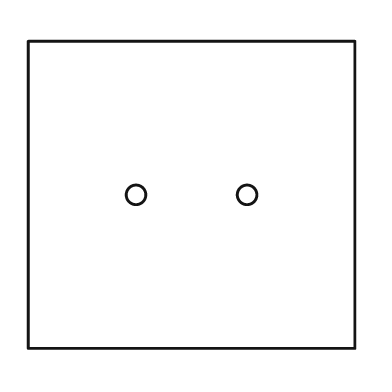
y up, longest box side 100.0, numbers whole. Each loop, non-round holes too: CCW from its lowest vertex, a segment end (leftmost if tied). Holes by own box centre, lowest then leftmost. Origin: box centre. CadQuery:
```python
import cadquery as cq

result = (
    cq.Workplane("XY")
    .moveTo(-50.0, -47.0)
    .lineTo(50.0, -47.0)
    .lineTo(50.0, 47.0)
    .lineTo(-50.0, 47.0)
    .close()
    .moveTo(-17.0, 0.0)
    .circle(3.0)
    .moveTo(17.0, 0.0)
    .circle(3.0)
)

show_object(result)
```